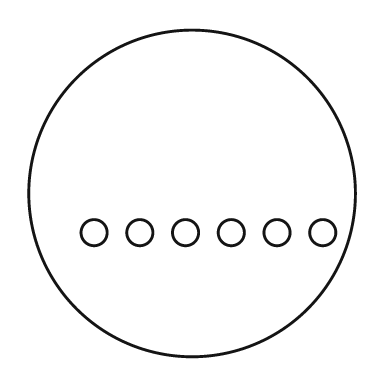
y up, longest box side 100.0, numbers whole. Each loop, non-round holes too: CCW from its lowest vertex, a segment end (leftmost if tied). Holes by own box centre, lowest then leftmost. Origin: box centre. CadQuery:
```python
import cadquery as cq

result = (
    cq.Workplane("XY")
    .moveTo(0.0, 0.0)
    .circle(50.0)
    .moveTo(-30.0, -12.0)
    .circle(4.0)
    .moveTo(-16.0, -12.0)
    .circle(4.0)
    .moveTo(-2.0, -12.0)
    .circle(4.0)
    .moveTo(12.0, -12.0)
    .circle(4.0)
    .moveTo(26.0, -12.0)
    .circle(4.0)
    .moveTo(40.0, -12.0)
    .circle(4.0)
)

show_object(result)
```